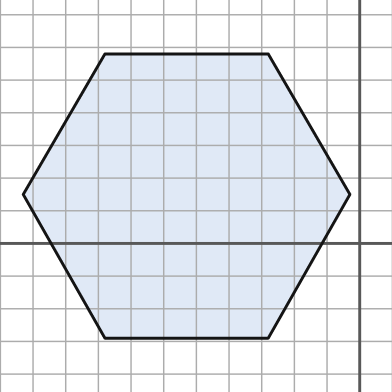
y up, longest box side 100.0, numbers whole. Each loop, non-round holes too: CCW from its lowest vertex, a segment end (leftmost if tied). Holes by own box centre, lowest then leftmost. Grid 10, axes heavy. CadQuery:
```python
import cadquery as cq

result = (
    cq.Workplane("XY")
    .moveTo(-78.0, -29.0)
    .lineTo(-28.0, -29.0)
    .lineTo(-3.0, 15.0)
    .lineTo(-28.0, 58.0)
    .lineTo(-78.0, 58.0)
    .lineTo(-103.0, 15.0)
    .close()
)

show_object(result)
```